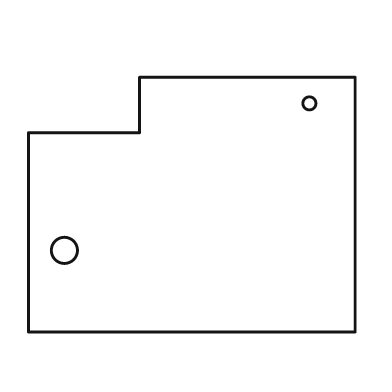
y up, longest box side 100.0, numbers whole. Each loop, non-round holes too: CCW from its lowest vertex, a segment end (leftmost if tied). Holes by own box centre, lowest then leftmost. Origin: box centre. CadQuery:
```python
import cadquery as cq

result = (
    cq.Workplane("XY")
    .moveTo(-50.0, -39.0)
    .lineTo(50.0, -39.0)
    .lineTo(50.0, 39.0)
    .lineTo(-16.0, 39.0)
    .lineTo(-16.0, 22.0)
    .lineTo(-50.0, 22.0)
    .close()
    .moveTo(-39.0, -14.0)
    .circle(4.0)
    .moveTo(36.0, 31.0)
    .circle(2.0)
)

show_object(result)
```